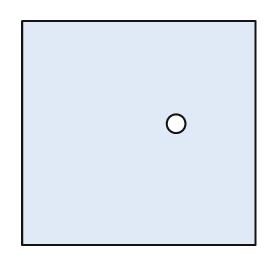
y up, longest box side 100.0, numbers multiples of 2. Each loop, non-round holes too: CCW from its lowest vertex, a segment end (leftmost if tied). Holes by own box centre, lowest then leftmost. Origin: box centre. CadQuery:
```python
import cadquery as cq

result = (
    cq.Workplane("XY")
    .moveTo(-50.0, -48.0)
    .lineTo(50.0, -48.0)
    .lineTo(50.0, 48.0)
    .lineTo(-50.0, 48.0)
    .close()
    .moveTo(16.0, 4.0)
    .circle(4.0)
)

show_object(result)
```